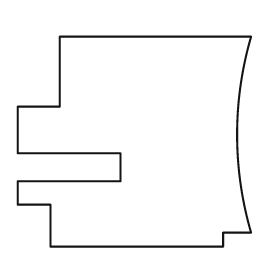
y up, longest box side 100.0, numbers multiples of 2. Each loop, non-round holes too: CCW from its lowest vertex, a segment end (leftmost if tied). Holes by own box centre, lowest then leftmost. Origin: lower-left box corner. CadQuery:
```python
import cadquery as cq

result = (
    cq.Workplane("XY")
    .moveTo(14.0, 0.0)
    .lineTo(88.0, 0.0)
    .lineTo(88.0, 6.0)
    .lineTo(100.0, 6.0)
    .threePointArc((94.0, 48.0), (100.0, 90.0))
    .lineTo(18.0, 90.0)
    .lineTo(18.0, 60.0)
    .lineTo(0.0, 60.0)
    .lineTo(0.0, 40.0)
    .lineTo(44.0, 40.0)
    .lineTo(44.0, 28.0)
    .lineTo(0.0, 28.0)
    .lineTo(0.0, 18.0)
    .lineTo(14.0, 18.0)
    .close()
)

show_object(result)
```